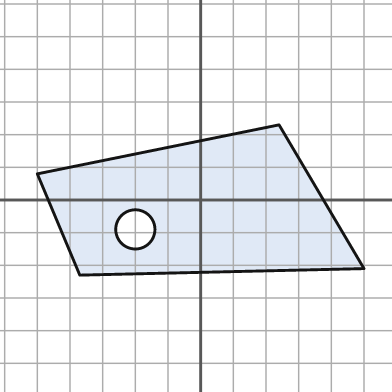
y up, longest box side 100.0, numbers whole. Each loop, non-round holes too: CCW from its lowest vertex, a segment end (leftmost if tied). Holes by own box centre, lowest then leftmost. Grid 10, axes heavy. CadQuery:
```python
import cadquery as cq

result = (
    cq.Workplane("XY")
    .moveTo(-37.0, -23.0)
    .lineTo(50.0, -21.0)
    .lineTo(24.0, 23.0)
    .lineTo(-50.0, 8.0)
    .close()
    .moveTo(-20.0, -9.0)
    .circle(6.0)
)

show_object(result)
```